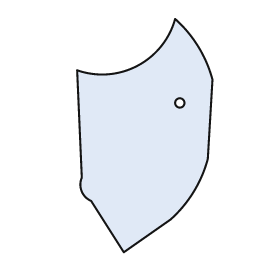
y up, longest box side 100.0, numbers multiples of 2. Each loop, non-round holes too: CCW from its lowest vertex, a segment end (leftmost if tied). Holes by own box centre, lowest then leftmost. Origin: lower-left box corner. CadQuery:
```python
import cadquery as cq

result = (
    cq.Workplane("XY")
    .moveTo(20.0, 0.0)
    .lineTo(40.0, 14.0)
    .threePointArc((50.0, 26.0), (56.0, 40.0))
    .lineTo(58.0, 74.0)
    .threePointArc((52.0, 88.0), (42.0, 100.0))
    .threePointArc((26.0, 80.0), (0.0, 78.0))
    .lineTo(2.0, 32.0)
    .threePointArc((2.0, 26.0), (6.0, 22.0))
    .close()
    .moveTo(44.0, 64.0)
    .circle(2.0)
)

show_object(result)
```